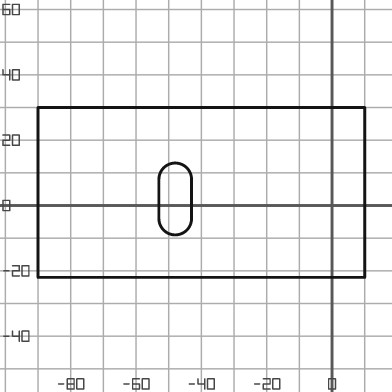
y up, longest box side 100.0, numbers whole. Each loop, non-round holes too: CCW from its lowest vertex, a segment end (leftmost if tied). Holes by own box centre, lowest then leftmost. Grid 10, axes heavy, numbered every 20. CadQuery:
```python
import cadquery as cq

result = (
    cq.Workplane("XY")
    .moveTo(-90.0, -22.0)
    .lineTo(10.0, -22.0)
    .lineTo(10.0, 30.0)
    .lineTo(-90.0, 30.0)
    .close()
    .moveTo(-53.0, -4.0)
    .threePointArc((-48.0, -9.0), (-43.0, -4.0))
    .lineTo(-43.0, 8.0)
    .threePointArc((-48.0, 13.0), (-53.0, 8.0))
    .close()
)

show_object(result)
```